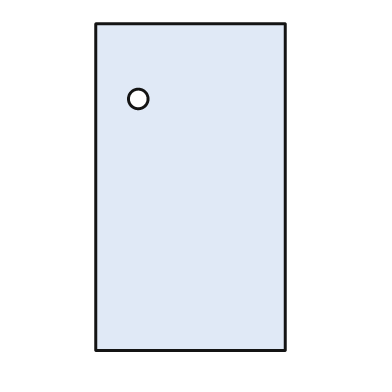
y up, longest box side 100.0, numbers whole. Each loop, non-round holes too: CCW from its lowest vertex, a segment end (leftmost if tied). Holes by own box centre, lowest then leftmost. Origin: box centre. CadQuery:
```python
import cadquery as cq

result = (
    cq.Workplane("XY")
    .moveTo(-29.0, -50.0)
    .lineTo(29.0, -50.0)
    .lineTo(29.0, 50.0)
    .lineTo(-29.0, 50.0)
    .close()
    .moveTo(-16.0, 27.0)
    .circle(3.0)
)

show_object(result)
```